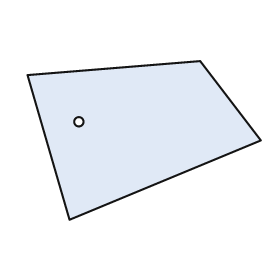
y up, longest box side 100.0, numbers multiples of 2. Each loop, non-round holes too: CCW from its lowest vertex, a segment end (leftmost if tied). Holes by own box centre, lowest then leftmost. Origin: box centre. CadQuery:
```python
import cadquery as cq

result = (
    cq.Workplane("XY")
    .moveTo(-32.0, -34.0)
    .lineTo(50.0, 0.0)
    .lineTo(24.0, 34.0)
    .lineTo(-50.0, 28.0)
    .close()
    .moveTo(-28.0, 8.0)
    .circle(2.0)
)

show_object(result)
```